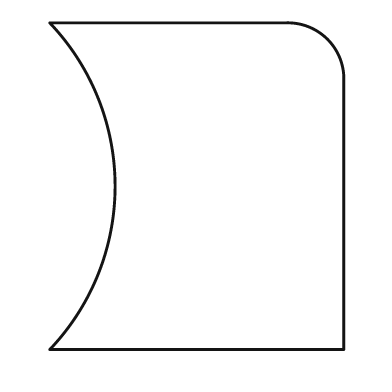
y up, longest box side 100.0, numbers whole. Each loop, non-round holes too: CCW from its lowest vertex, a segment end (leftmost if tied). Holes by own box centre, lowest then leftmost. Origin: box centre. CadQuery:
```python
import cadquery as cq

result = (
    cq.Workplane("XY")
    .moveTo(-45.0, -50.0)
    .lineTo(45.0, -50.0)
    .lineTo(45.0, 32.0)
    .threePointArc((40.0, 45.0), (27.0, 50.0))
    .lineTo(-45.0, 50.0)
    .threePointArc((-25.0, 0.0), (-45.0, -50.0))
    .close()
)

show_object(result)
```